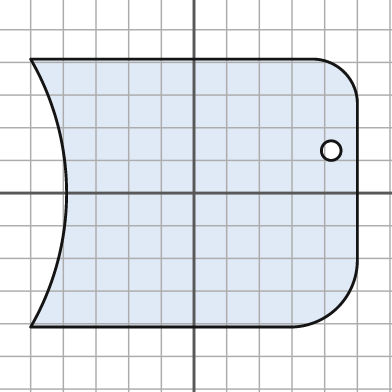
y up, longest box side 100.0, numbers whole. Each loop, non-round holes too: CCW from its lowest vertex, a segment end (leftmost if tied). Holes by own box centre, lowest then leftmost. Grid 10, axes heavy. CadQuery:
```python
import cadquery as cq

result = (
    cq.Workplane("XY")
    .moveTo(-50.0, -41.0)
    .lineTo(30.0, -41.0)
    .threePointArc((44.0, -35.0), (50.0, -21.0))
    .lineTo(50.0, 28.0)
    .threePointArc((46.0, 37.0), (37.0, 41.0))
    .lineTo(-50.0, 41.0)
    .threePointArc((-39.0, 0.0), (-50.0, -41.0))
    .close()
    .moveTo(42.0, 13.0)
    .circle(3.0)
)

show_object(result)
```